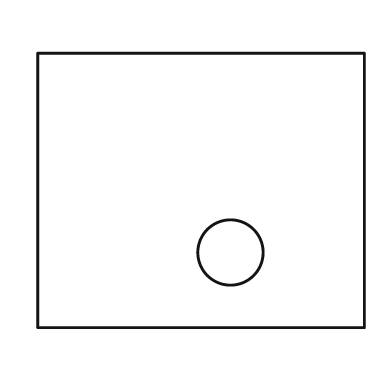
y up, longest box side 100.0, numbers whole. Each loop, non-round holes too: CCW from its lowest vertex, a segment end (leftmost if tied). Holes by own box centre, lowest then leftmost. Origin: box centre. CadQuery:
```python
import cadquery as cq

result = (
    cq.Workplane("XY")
    .moveTo(-50.0, -42.0)
    .lineTo(50.0, -42.0)
    .lineTo(50.0, 42.0)
    .lineTo(-50.0, 42.0)
    .close()
    .moveTo(9.0, -19.0)
    .circle(10.0)
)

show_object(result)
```